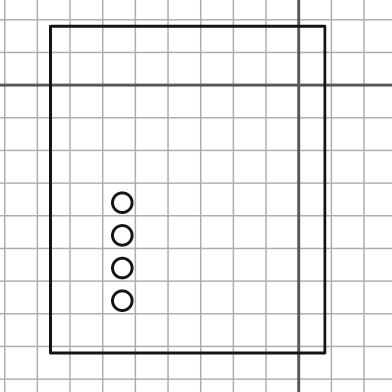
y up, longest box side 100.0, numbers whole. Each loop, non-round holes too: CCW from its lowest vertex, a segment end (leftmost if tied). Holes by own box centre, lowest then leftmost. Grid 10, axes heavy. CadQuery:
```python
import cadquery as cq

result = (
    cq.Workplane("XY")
    .moveTo(-76.0, -82.0)
    .lineTo(8.0, -82.0)
    .lineTo(8.0, 18.0)
    .lineTo(-76.0, 18.0)
    .close()
    .moveTo(-54.0, -66.0)
    .circle(3.0)
    .moveTo(-54.0, -56.0)
    .circle(3.0)
    .moveTo(-54.0, -46.0)
    .circle(3.0)
    .moveTo(-54.0, -36.0)
    .circle(3.0)
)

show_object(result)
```